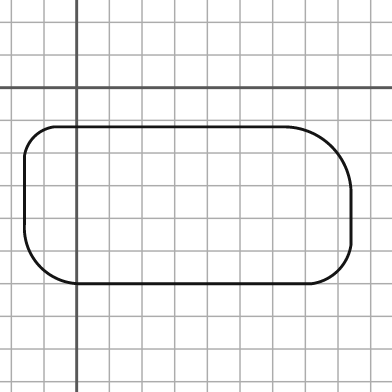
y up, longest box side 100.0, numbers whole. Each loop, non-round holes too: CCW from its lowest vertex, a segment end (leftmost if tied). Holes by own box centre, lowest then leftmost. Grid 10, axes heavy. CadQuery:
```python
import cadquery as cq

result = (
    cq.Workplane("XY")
    .moveTo(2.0, -60.0)
    .lineTo(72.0, -60.0)
    .threePointArc((80.0, -56.0), (84.0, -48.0))
    .lineTo(84.0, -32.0)
    .threePointArc((78.0, -18.0), (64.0, -12.0))
    .lineTo(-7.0, -12.0)
    .threePointArc((-13.0, -15.0), (-16.0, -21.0))
    .lineTo(-16.0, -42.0)
    .threePointArc((-11.0, -55.0), (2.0, -60.0))
    .close()
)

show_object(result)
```